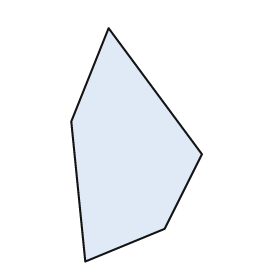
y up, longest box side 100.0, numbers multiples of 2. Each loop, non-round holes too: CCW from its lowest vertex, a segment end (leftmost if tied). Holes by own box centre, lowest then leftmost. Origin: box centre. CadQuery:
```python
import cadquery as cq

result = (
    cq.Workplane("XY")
    .moveTo(-22.0, -50.0)
    .lineTo(12.0, -36.0)
    .lineTo(28.0, -4.0)
    .lineTo(-12.0, 50.0)
    .lineTo(-28.0, 10.0)
    .close()
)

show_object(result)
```